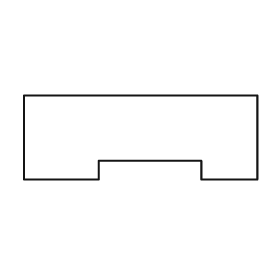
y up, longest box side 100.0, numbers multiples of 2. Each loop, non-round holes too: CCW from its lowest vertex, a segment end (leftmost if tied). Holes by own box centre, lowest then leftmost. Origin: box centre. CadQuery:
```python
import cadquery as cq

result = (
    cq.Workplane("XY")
    .moveTo(-50.0, -18.0)
    .lineTo(-18.0, -18.0)
    .lineTo(-18.0, -10.0)
    .lineTo(26.0, -10.0)
    .lineTo(26.0, -18.0)
    .lineTo(50.0, -18.0)
    .lineTo(50.0, 18.0)
    .lineTo(-50.0, 18.0)
    .close()
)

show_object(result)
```